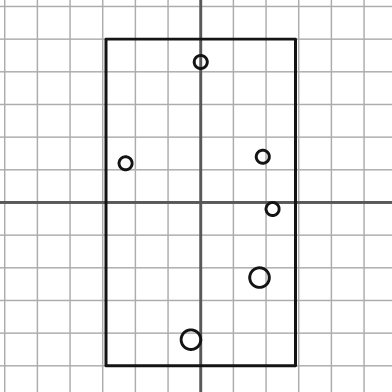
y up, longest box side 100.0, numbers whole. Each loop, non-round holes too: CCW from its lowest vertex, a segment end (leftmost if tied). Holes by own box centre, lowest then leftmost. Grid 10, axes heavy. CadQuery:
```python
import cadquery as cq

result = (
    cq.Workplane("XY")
    .moveTo(-29.0, -50.0)
    .lineTo(29.0, -50.0)
    .lineTo(29.0, 50.0)
    .lineTo(-29.0, 50.0)
    .close()
    .moveTo(-3.0, -42.0)
    .circle(3.0)
    .moveTo(18.0, -23.0)
    .circle(3.0)
    .moveTo(22.0, -2.0)
    .circle(2.0)
    .moveTo(-23.0, 12.0)
    .circle(2.0)
    .moveTo(19.0, 14.0)
    .circle(2.0)
    .moveTo(0.0, 43.0)
    .circle(2.0)
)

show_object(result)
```